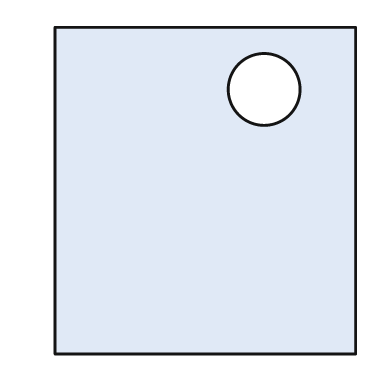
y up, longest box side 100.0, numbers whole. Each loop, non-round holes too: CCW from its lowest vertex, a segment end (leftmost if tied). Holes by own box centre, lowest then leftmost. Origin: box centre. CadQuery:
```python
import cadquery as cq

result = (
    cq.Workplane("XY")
    .moveTo(-46.0, -50.0)
    .lineTo(46.0, -50.0)
    .lineTo(46.0, 50.0)
    .lineTo(-46.0, 50.0)
    .close()
    .moveTo(18.0, 31.0)
    .circle(11.0)
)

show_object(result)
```